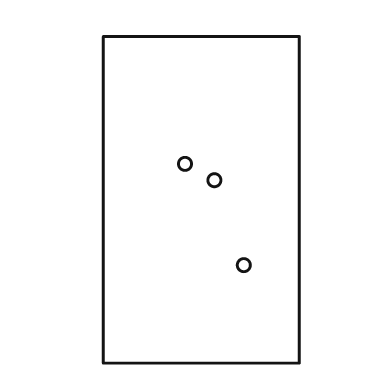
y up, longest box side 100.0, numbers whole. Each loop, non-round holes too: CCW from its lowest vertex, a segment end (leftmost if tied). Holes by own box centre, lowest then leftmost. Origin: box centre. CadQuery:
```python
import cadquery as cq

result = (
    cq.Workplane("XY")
    .moveTo(-30.0, -50.0)
    .lineTo(30.0, -50.0)
    .lineTo(30.0, 50.0)
    .lineTo(-30.0, 50.0)
    .close()
    .moveTo(13.0, -20.0)
    .circle(2.0)
    .moveTo(4.0, 6.0)
    .circle(2.0)
    .moveTo(-5.0, 11.0)
    .circle(2.0)
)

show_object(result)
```